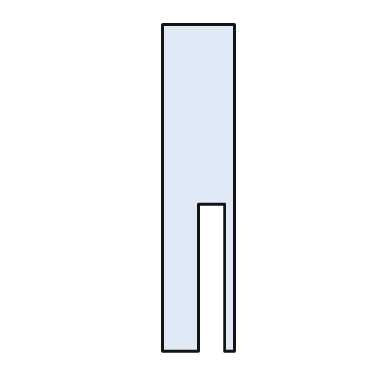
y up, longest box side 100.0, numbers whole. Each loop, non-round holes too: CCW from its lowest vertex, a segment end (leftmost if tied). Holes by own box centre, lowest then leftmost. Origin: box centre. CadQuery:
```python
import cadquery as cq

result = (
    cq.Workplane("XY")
    .moveTo(-11.0, -50.0)
    .lineTo(0.0, -50.0)
    .lineTo(0.0, -5.0)
    .lineTo(8.0, -5.0)
    .lineTo(8.0, -50.0)
    .lineTo(11.0, -50.0)
    .lineTo(11.0, 50.0)
    .lineTo(-11.0, 50.0)
    .close()
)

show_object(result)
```